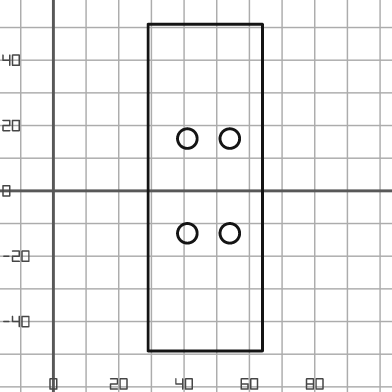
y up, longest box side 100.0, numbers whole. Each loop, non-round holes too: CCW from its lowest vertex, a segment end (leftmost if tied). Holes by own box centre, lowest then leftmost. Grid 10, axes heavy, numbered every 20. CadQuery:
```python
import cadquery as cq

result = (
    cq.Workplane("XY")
    .moveTo(29.0, -49.0)
    .lineTo(64.0, -49.0)
    .lineTo(64.0, 51.0)
    .lineTo(29.0, 51.0)
    .close()
    .moveTo(41.0, -13.0)
    .circle(3.0)
    .moveTo(54.0, -13.0)
    .circle(3.0)
    .moveTo(41.0, 16.0)
    .circle(3.0)
    .moveTo(54.0, 16.0)
    .circle(3.0)
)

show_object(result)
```